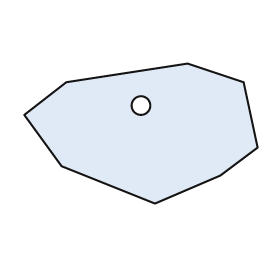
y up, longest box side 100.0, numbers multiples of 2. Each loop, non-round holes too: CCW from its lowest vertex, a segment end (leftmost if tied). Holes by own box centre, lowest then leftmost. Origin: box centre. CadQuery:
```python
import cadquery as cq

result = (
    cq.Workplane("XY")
    .moveTo(6.0, -30.0)
    .lineTo(34.0, -18.0)
    .lineTo(50.0, -6.0)
    .lineTo(44.0, 22.0)
    .lineTo(20.0, 30.0)
    .lineTo(-32.0, 22.0)
    .lineTo(-50.0, 8.0)
    .lineTo(-34.0, -14.0)
    .close()
    .moveTo(0.0, 12.0)
    .circle(4.0)
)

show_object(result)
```